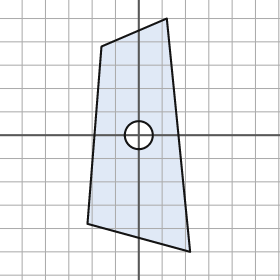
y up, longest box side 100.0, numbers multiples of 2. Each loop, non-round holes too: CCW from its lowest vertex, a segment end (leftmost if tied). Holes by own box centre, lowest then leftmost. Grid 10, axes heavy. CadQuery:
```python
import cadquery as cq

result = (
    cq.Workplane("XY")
    .moveTo(22.0, -50.0)
    .lineTo(12.0, 50.0)
    .lineTo(-16.0, 38.0)
    .lineTo(-22.0, -38.0)
    .close()
    .moveTo(0.0, 0.0)
    .circle(6.0)
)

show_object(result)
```